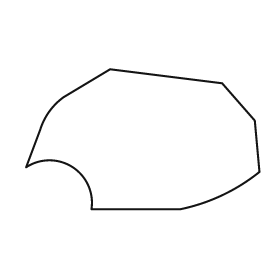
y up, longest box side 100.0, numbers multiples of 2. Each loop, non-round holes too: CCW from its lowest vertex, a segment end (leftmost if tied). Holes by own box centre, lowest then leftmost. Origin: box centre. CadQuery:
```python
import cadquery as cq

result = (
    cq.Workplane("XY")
    .moveTo(-22.0, -30.0)
    .lineTo(16.0, -30.0)
    .threePointArc((34.0, -24.0), (50.0, -14.0))
    .lineTo(48.0, 8.0)
    .lineTo(34.0, 24.0)
    .lineTo(-14.0, 30.0)
    .lineTo(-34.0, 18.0)
    .threePointArc((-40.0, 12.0), (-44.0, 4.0))
    .lineTo(-50.0, -12.0)
    .threePointArc((-30.0, -12.0), (-22.0, -30.0))
    .close()
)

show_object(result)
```